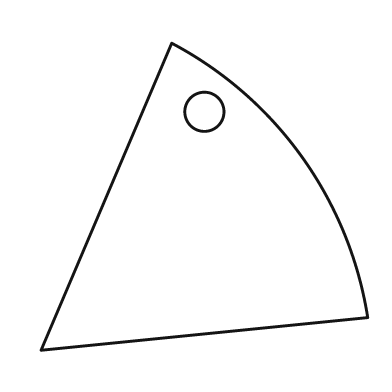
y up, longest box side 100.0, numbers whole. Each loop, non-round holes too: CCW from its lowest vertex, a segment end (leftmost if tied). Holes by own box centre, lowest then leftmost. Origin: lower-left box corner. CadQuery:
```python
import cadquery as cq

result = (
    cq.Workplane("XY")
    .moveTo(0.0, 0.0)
    .lineTo(100.0, 10.0)
    .threePointArc((80.0, 59.0), (40.0, 94.0))
    .close()
    .moveTo(50.0, 73.0)
    .circle(6.0)
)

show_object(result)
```